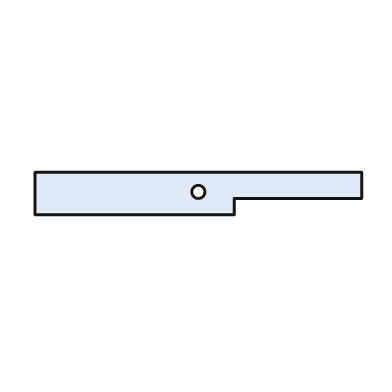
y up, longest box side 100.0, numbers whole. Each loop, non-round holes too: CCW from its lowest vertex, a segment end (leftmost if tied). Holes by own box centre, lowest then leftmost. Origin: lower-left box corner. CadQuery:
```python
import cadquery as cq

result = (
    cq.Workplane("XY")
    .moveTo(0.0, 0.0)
    .lineTo(61.0, 0.0)
    .lineTo(61.0, 5.0)
    .lineTo(100.0, 5.0)
    .lineTo(100.0, 13.0)
    .lineTo(0.0, 13.0)
    .close()
    .moveTo(50.0, 7.0)
    .circle(2.0)
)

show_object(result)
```